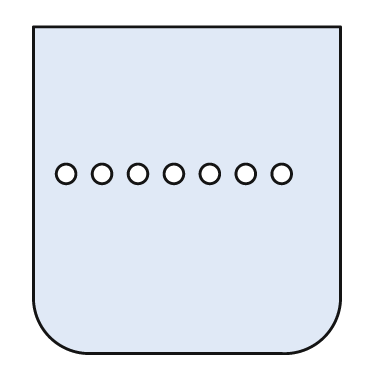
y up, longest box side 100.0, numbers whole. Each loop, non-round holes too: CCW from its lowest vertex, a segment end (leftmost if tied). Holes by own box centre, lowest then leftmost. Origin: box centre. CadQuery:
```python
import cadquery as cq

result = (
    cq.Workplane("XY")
    .moveTo(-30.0, -50.0)
    .lineTo(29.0, -50.0)
    .threePointArc((42.0, -45.0), (47.0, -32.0))
    .lineTo(47.0, 50.0)
    .lineTo(-47.0, 50.0)
    .lineTo(-47.0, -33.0)
    .threePointArc((-42.0, -45.0), (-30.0, -50.0))
    .close()
    .moveTo(-37.0, 5.0)
    .circle(3.0)
    .moveTo(-26.0, 5.0)
    .circle(3.0)
    .moveTo(-15.0, 5.0)
    .circle(3.0)
    .moveTo(-4.0, 5.0)
    .circle(3.0)
    .moveTo(7.0, 5.0)
    .circle(3.0)
    .moveTo(18.0, 5.0)
    .circle(3.0)
    .moveTo(29.0, 5.0)
    .circle(3.0)
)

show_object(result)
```